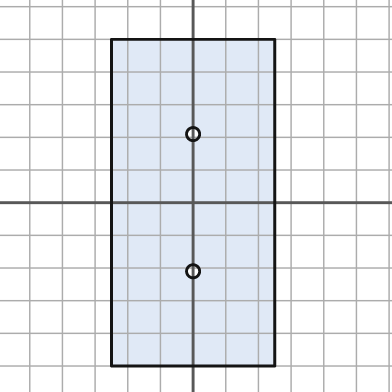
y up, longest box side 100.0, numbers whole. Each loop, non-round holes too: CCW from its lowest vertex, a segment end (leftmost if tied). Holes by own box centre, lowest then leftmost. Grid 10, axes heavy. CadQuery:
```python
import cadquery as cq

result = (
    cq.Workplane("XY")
    .moveTo(-25.0, -50.0)
    .lineTo(25.0, -50.0)
    .lineTo(25.0, 50.0)
    .lineTo(-25.0, 50.0)
    .close()
    .moveTo(0.0, -21.0)
    .circle(2.0)
    .moveTo(0.0, 21.0)
    .circle(2.0)
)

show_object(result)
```